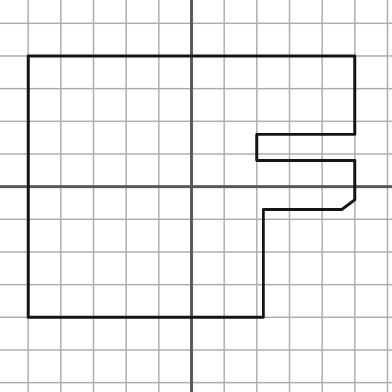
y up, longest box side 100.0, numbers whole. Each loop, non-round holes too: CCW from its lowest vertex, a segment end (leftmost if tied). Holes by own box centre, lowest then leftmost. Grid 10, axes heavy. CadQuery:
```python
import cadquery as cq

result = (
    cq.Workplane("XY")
    .moveTo(-50.0, -40.0)
    .lineTo(22.0, -40.0)
    .lineTo(22.0, -7.0)
    .lineTo(46.0, -7.0)
    .lineTo(50.0, -4.0)
    .lineTo(50.0, 8.0)
    .lineTo(20.0, 8.0)
    .lineTo(20.0, 16.0)
    .lineTo(50.0, 16.0)
    .lineTo(50.0, 40.0)
    .lineTo(-50.0, 40.0)
    .close()
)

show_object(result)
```